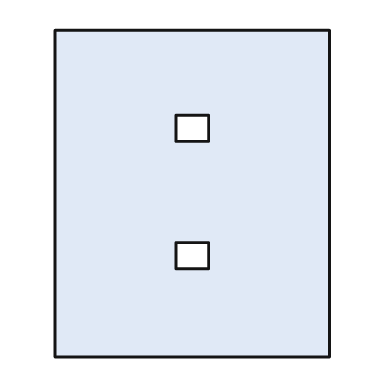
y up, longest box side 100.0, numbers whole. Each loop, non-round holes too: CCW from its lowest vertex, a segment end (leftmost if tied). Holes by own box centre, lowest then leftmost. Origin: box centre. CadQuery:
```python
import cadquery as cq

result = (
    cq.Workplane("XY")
    .moveTo(-42.0, -50.0)
    .lineTo(42.0, -50.0)
    .lineTo(42.0, 50.0)
    .lineTo(-42.0, 50.0)
    .close()
    .moveTo(-5.0, -23.0)
    .lineTo(5.0, -23.0)
    .lineTo(5.0, -15.0)
    .lineTo(-5.0, -15.0)
    .close()
    .moveTo(-5.0, 16.0)
    .lineTo(5.0, 16.0)
    .lineTo(5.0, 24.0)
    .lineTo(-5.0, 24.0)
    .close()
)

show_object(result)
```